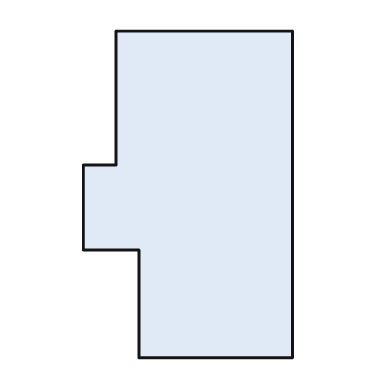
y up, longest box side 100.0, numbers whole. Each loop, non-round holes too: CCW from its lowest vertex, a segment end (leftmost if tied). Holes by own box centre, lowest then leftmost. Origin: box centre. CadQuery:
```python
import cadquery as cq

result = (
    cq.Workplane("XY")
    .moveTo(-15.0, -50.0)
    .lineTo(32.0, -50.0)
    .lineTo(32.0, 50.0)
    .lineTo(-22.0, 50.0)
    .lineTo(-22.0, 9.0)
    .lineTo(-32.0, 9.0)
    .lineTo(-32.0, -17.0)
    .lineTo(-15.0, -17.0)
    .close()
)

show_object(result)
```